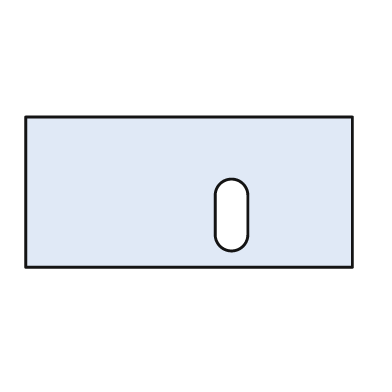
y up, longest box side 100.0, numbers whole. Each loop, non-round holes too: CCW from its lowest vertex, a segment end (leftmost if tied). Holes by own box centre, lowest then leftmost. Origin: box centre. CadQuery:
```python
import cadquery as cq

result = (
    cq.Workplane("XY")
    .moveTo(-50.0, -23.0)
    .lineTo(50.0, -23.0)
    .lineTo(50.0, 23.0)
    .lineTo(-50.0, 23.0)
    .close()
    .moveTo(8.0, -13.0)
    .threePointArc((13.0, -18.0), (18.0, -13.0))
    .lineTo(18.0, -1.0)
    .threePointArc((13.0, 4.0), (8.0, -1.0))
    .close()
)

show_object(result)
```